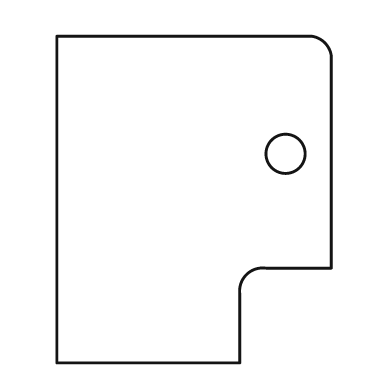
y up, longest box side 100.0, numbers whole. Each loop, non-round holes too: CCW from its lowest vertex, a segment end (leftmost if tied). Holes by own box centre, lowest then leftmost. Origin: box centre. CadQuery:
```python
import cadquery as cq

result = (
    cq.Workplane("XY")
    .moveTo(-42.0, -50.0)
    .lineTo(14.0, -50.0)
    .lineTo(14.0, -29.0)
    .threePointArc((16.0, -23.0), (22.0, -21.0))
    .lineTo(42.0, -21.0)
    .lineTo(42.0, 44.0)
    .threePointArc((40.0, 48.0), (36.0, 50.0))
    .lineTo(-42.0, 50.0)
    .close()
    .moveTo(28.0, 14.0)
    .circle(6.0)
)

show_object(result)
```